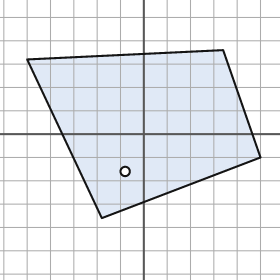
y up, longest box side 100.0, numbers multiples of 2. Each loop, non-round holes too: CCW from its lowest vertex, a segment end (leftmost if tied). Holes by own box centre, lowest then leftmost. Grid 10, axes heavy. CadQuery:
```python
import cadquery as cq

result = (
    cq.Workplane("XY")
    .moveTo(-18.0, -36.0)
    .lineTo(50.0, -10.0)
    .lineTo(34.0, 36.0)
    .lineTo(-50.0, 32.0)
    .close()
    .moveTo(-8.0, -16.0)
    .circle(2.0)
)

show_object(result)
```